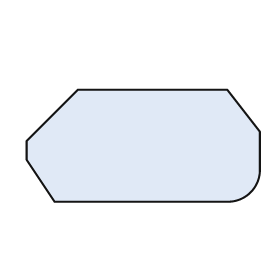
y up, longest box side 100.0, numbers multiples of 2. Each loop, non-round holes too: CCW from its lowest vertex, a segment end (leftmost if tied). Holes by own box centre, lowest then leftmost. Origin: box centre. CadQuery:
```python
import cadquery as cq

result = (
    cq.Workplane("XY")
    .moveTo(-38.0, -24.0)
    .lineTo(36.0, -24.0)
    .threePointArc((46.0, -20.0), (50.0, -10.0))
    .lineTo(50.0, 6.0)
    .lineTo(36.0, 24.0)
    .lineTo(-28.0, 24.0)
    .lineTo(-50.0, 2.0)
    .lineTo(-50.0, -6.0)
    .close()
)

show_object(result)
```